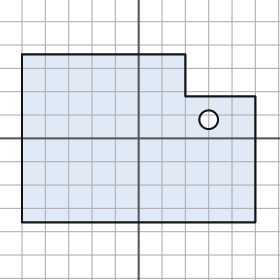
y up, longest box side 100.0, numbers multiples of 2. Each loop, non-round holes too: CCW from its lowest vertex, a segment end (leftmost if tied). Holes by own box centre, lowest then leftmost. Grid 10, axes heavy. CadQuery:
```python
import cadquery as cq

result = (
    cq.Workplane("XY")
    .moveTo(-50.0, -36.0)
    .lineTo(50.0, -36.0)
    .lineTo(50.0, 18.0)
    .lineTo(20.0, 18.0)
    .lineTo(20.0, 36.0)
    .lineTo(-50.0, 36.0)
    .close()
    .moveTo(30.0, 8.0)
    .circle(4.0)
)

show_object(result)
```